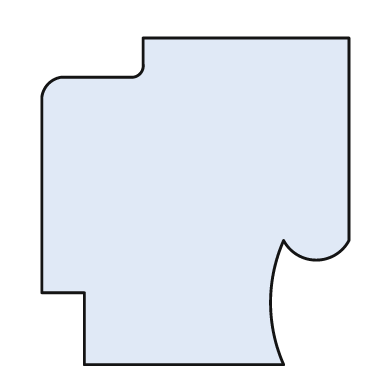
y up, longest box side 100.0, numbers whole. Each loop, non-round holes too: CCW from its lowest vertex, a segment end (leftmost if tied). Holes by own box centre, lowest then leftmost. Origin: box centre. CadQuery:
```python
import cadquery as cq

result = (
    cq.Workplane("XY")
    .moveTo(-34.0, -50.0)
    .lineTo(27.0, -50.0)
    .threePointArc((23.0, -31.0), (27.0, -12.0))
    .threePointArc((37.0, -18.0), (47.0, -12.0))
    .lineTo(47.0, 50.0)
    .lineTo(-16.0, 50.0)
    .lineTo(-16.0, 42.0)
    .threePointArc((-17.0, 39.0), (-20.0, 38.0))
    .lineTo(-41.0, 38.0)
    .threePointArc((-45.0, 36.0), (-47.0, 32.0))
    .lineTo(-47.0, -28.0)
    .lineTo(-34.0, -28.0)
    .close()
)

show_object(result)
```